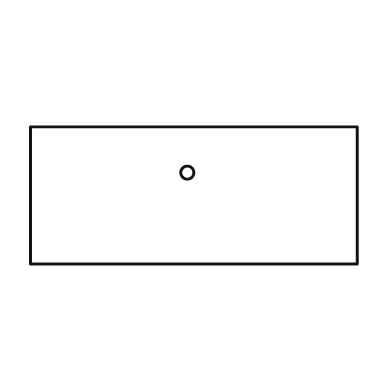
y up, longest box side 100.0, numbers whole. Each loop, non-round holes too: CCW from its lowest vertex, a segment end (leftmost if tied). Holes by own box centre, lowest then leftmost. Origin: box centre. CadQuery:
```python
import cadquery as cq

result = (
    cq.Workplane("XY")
    .moveTo(-50.0, -21.0)
    .lineTo(50.0, -21.0)
    .lineTo(50.0, 21.0)
    .lineTo(-50.0, 21.0)
    .close()
    .moveTo(-2.0, 7.0)
    .circle(2.0)
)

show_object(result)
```